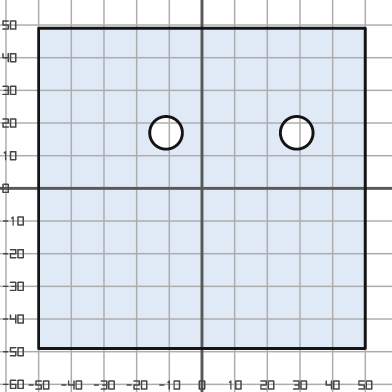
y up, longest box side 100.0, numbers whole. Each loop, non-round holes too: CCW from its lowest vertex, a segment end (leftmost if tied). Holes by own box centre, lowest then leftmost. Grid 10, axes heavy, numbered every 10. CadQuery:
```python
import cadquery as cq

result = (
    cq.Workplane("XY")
    .moveTo(-50.0, -49.0)
    .lineTo(50.0, -49.0)
    .lineTo(50.0, 49.0)
    .lineTo(-50.0, 49.0)
    .close()
    .moveTo(-11.0, 17.0)
    .circle(5.0)
    .moveTo(29.0, 17.0)
    .circle(5.0)
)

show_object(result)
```